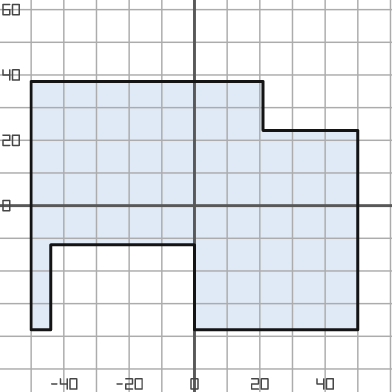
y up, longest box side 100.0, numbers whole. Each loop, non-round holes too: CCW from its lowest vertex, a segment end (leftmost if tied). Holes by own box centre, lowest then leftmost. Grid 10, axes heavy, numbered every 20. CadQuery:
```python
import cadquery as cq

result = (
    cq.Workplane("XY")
    .moveTo(-50.0, -38.0)
    .lineTo(-44.0, -38.0)
    .lineTo(-44.0, -12.0)
    .lineTo(0.0, -12.0)
    .lineTo(0.0, -38.0)
    .lineTo(50.0, -38.0)
    .lineTo(50.0, 23.0)
    .lineTo(21.0, 23.0)
    .lineTo(21.0, 38.0)
    .lineTo(-50.0, 38.0)
    .close()
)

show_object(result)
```